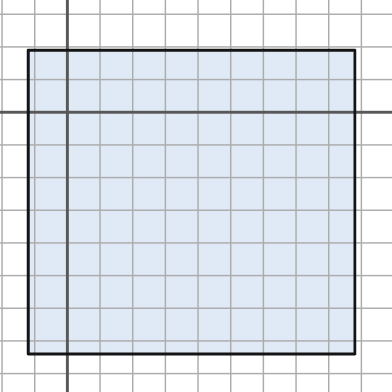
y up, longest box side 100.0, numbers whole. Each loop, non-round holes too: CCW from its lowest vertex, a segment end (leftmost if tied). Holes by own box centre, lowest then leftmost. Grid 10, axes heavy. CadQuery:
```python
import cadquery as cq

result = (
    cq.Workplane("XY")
    .moveTo(-12.0, -74.0)
    .lineTo(88.0, -74.0)
    .lineTo(88.0, 19.0)
    .lineTo(-12.0, 19.0)
    .close()
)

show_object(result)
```